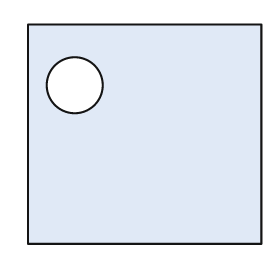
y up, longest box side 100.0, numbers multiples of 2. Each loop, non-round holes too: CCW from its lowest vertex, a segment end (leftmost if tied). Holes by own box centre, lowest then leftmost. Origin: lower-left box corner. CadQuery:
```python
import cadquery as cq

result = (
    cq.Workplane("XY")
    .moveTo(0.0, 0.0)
    .lineTo(100.0, 0.0)
    .lineTo(100.0, 94.0)
    .lineTo(0.0, 94.0)
    .close()
    .moveTo(20.0, 68.0)
    .circle(12.0)
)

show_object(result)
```